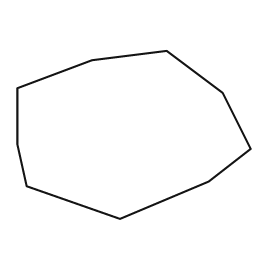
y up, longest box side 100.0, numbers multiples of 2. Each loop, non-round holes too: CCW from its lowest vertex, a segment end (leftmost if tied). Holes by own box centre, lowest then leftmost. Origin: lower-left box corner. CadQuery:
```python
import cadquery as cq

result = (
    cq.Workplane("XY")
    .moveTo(44.0, 0.0)
    .lineTo(82.0, 16.0)
    .lineTo(100.0, 30.0)
    .lineTo(88.0, 54.0)
    .lineTo(64.0, 72.0)
    .lineTo(32.0, 68.0)
    .lineTo(0.0, 56.0)
    .lineTo(0.0, 32.0)
    .lineTo(4.0, 14.0)
    .close()
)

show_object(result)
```